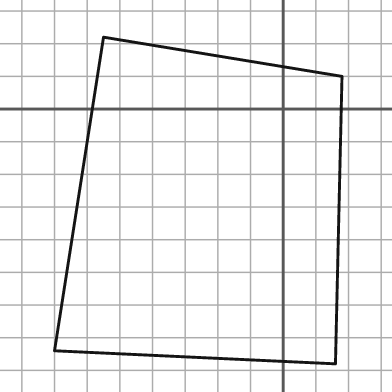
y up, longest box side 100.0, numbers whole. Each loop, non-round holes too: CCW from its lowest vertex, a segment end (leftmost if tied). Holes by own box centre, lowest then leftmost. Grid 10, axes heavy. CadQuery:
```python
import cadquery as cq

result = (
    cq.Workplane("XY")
    .moveTo(16.0, -78.0)
    .lineTo(18.0, 10.0)
    .lineTo(-55.0, 22.0)
    .lineTo(-70.0, -74.0)
    .close()
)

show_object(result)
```